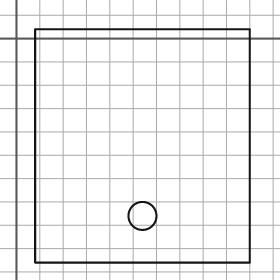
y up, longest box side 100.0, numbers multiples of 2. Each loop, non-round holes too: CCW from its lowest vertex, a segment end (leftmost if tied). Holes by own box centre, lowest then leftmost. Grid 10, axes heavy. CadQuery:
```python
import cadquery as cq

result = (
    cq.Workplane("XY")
    .moveTo(8.0, -96.0)
    .lineTo(100.0, -96.0)
    .lineTo(100.0, 4.0)
    .lineTo(8.0, 4.0)
    .close()
    .moveTo(54.0, -76.0)
    .circle(6.0)
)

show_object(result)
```